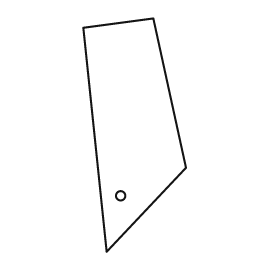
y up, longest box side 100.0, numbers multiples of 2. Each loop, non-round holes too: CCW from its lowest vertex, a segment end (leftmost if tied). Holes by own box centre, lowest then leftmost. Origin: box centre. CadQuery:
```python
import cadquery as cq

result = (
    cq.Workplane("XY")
    .moveTo(-12.0, -50.0)
    .lineTo(22.0, -14.0)
    .lineTo(8.0, 50.0)
    .lineTo(-22.0, 46.0)
    .close()
    .moveTo(-6.0, -26.0)
    .circle(2.0)
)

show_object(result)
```